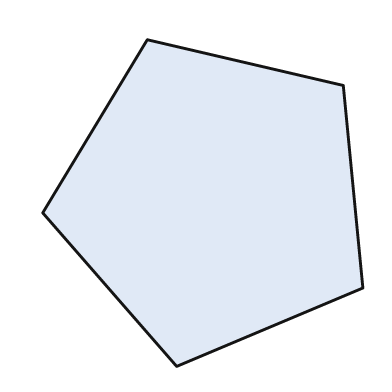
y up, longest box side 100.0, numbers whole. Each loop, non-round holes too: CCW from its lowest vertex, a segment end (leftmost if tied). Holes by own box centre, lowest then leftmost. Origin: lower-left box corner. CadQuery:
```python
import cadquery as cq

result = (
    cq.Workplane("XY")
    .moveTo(41.0, 0.0)
    .lineTo(98.0, 24.0)
    .lineTo(92.0, 86.0)
    .lineTo(32.0, 100.0)
    .lineTo(0.0, 47.0)
    .close()
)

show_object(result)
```